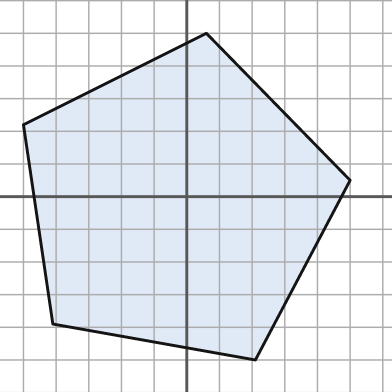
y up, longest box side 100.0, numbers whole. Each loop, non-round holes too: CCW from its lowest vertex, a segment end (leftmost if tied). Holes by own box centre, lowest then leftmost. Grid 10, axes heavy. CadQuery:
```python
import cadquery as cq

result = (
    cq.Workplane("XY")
    .moveTo(21.0, -50.0)
    .lineTo(50.0, 5.0)
    .lineTo(6.0, 50.0)
    .lineTo(-50.0, 22.0)
    .lineTo(-41.0, -39.0)
    .close()
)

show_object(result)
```